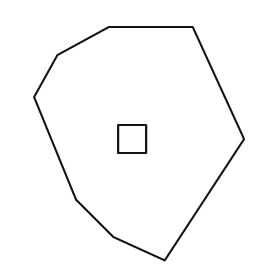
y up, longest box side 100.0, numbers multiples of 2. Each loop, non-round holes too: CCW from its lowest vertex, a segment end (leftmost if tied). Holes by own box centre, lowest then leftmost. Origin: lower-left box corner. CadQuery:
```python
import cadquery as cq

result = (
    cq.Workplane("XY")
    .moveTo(56.0, 0.0)
    .lineTo(90.0, 52.0)
    .lineTo(68.0, 100.0)
    .lineTo(32.0, 100.0)
    .lineTo(10.0, 88.0)
    .lineTo(0.0, 70.0)
    .lineTo(18.0, 26.0)
    .lineTo(34.0, 10.0)
    .close()
    .moveTo(36.0, 46.0)
    .lineTo(48.0, 46.0)
    .lineTo(48.0, 58.0)
    .lineTo(36.0, 58.0)
    .close()
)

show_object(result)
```